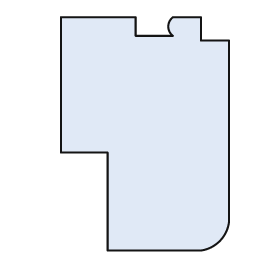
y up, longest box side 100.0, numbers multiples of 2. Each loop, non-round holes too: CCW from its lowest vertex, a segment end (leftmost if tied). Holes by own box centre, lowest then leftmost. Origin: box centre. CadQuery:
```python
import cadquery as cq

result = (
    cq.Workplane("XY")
    .moveTo(-16.0, -50.0)
    .lineTo(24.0, -50.0)
    .threePointArc((32.0, -46.0), (36.0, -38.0))
    .lineTo(36.0, 40.0)
    .lineTo(24.0, 40.0)
    .lineTo(24.0, 50.0)
    .lineTo(12.0, 50.0)
    .threePointArc((10.0, 46.0), (12.0, 42.0))
    .lineTo(-4.0, 42.0)
    .lineTo(-4.0, 50.0)
    .lineTo(-36.0, 50.0)
    .lineTo(-36.0, -8.0)
    .lineTo(-16.0, -8.0)
    .close()
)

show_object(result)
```